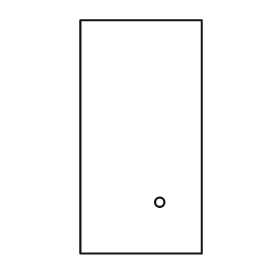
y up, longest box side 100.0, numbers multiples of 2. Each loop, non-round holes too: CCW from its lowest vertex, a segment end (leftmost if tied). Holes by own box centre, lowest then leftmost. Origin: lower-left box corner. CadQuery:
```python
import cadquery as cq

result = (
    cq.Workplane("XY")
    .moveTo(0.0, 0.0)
    .lineTo(52.0, 0.0)
    .lineTo(52.0, 100.0)
    .lineTo(0.0, 100.0)
    .close()
    .moveTo(34.0, 22.0)
    .circle(2.0)
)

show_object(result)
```